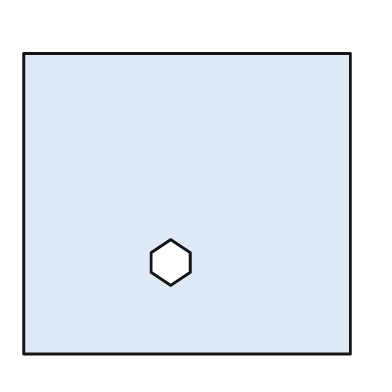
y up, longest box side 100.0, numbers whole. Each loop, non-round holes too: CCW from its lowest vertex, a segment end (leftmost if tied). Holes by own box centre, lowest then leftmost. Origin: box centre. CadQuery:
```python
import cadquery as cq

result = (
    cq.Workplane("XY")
    .moveTo(-50.0, -46.0)
    .lineTo(50.0, -46.0)
    .lineTo(50.0, 46.0)
    .lineTo(-50.0, 46.0)
    .close()
    .moveTo(-5.0, -25.0)
    .lineTo(1.0, -21.0)
    .lineTo(1.0, -15.0)
    .lineTo(-5.0, -11.0)
    .lineTo(-11.0, -15.0)
    .lineTo(-11.0, -21.0)
    .close()
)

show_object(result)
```